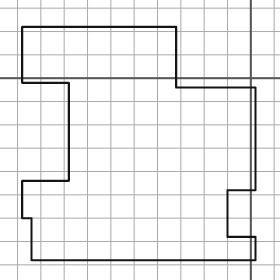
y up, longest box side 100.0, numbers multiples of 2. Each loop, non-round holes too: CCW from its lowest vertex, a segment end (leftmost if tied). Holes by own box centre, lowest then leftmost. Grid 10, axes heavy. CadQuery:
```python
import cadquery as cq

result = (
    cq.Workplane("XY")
    .moveTo(-94.0, -78.0)
    .lineTo(2.0, -78.0)
    .lineTo(2.0, -68.0)
    .lineTo(-10.0, -68.0)
    .lineTo(-10.0, -48.0)
    .lineTo(2.0, -48.0)
    .lineTo(2.0, -4.0)
    .lineTo(-32.0, -4.0)
    .lineTo(-32.0, 22.0)
    .lineTo(-98.0, 22.0)
    .lineTo(-98.0, -2.0)
    .lineTo(-78.0, -2.0)
    .lineTo(-78.0, -44.0)
    .lineTo(-98.0, -44.0)
    .lineTo(-98.0, -60.0)
    .lineTo(-94.0, -60.0)
    .close()
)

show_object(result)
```